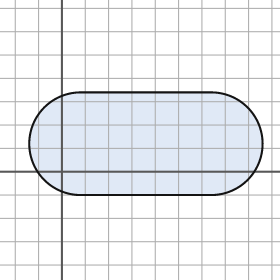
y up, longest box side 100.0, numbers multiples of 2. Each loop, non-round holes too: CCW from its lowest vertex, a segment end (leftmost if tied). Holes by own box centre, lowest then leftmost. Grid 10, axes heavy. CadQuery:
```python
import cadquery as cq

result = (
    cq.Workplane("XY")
    .moveTo(8.0, -10.0)
    .lineTo(64.0, -10.0)
    .threePointArc((86.0, 12.0), (64.0, 34.0))
    .lineTo(8.0, 34.0)
    .threePointArc((-14.0, 12.0), (8.0, -10.0))
    .close()
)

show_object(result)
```